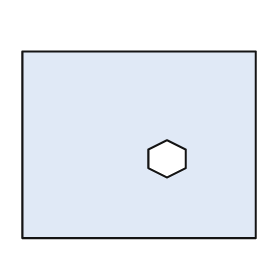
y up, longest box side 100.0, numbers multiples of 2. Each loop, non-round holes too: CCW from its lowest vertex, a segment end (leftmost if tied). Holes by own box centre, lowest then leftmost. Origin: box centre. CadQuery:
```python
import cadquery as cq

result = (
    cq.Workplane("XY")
    .moveTo(-50.0, -40.0)
    .lineTo(50.0, -40.0)
    .lineTo(50.0, 40.0)
    .lineTo(-50.0, 40.0)
    .close()
    .moveTo(12.0, -14.0)
    .lineTo(20.0, -10.0)
    .lineTo(20.0, -2.0)
    .lineTo(12.0, 2.0)
    .lineTo(4.0, -2.0)
    .lineTo(4.0, -10.0)
    .close()
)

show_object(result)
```